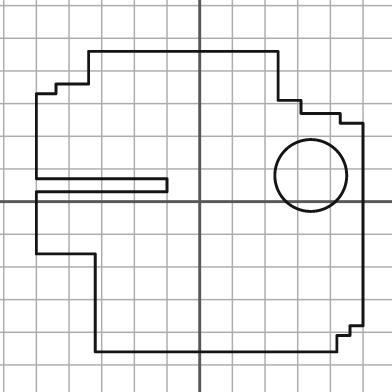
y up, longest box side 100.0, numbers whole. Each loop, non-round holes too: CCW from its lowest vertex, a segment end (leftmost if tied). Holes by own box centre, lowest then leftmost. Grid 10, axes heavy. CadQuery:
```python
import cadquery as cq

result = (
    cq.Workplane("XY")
    .moveTo(-32.0, -46.0)
    .lineTo(42.0, -46.0)
    .lineTo(42.0, -41.0)
    .lineTo(46.0, -41.0)
    .lineTo(46.0, -38.0)
    .lineTo(50.0, -38.0)
    .lineTo(50.0, 24.0)
    .lineTo(43.0, 24.0)
    .lineTo(43.0, 27.0)
    .lineTo(31.0, 27.0)
    .lineTo(31.0, 31.0)
    .lineTo(24.0, 31.0)
    .lineTo(24.0, 46.0)
    .lineTo(-34.0, 46.0)
    .lineTo(-34.0, 36.0)
    .lineTo(-44.0, 36.0)
    .lineTo(-44.0, 33.0)
    .lineTo(-50.0, 33.0)
    .lineTo(-50.0, 7.0)
    .lineTo(-10.0, 7.0)
    .lineTo(-10.0, 3.0)
    .lineTo(-50.0, 3.0)
    .lineTo(-50.0, -16.0)
    .lineTo(-32.0, -16.0)
    .close()
    .moveTo(34.0, 8.0)
    .circle(11.0)
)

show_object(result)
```